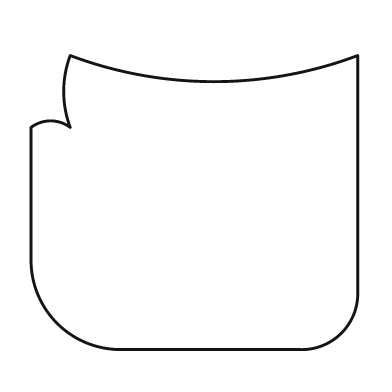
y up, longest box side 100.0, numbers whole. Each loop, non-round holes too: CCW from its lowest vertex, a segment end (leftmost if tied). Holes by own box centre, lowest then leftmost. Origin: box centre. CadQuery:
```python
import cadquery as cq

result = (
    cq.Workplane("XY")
    .moveTo(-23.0, -45.0)
    .lineTo(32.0, -45.0)
    .threePointArc((45.0, -40.0), (50.0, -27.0))
    .lineTo(50.0, 45.0)
    .threePointArc((6.0, 37.0), (-38.0, 45.0))
    .threePointArc((-40.0, 34.0), (-38.0, 23.0))
    .threePointArc((-44.0, 25.0), (-50.0, 23.0))
    .lineTo(-50.0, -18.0)
    .threePointArc((-42.0, -37.0), (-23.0, -45.0))
    .close()
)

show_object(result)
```